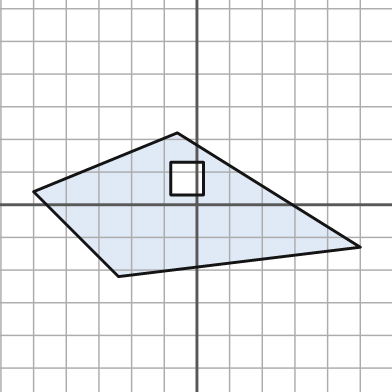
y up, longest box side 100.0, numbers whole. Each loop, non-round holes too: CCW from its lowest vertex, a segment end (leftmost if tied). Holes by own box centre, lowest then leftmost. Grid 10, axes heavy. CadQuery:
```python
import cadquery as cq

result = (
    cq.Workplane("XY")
    .moveTo(-24.0, -22.0)
    .lineTo(50.0, -13.0)
    .lineTo(-6.0, 22.0)
    .lineTo(-50.0, 4.0)
    .close()
    .moveTo(-8.0, 3.0)
    .lineTo(2.0, 3.0)
    .lineTo(2.0, 13.0)
    .lineTo(-8.0, 13.0)
    .close()
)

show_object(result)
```